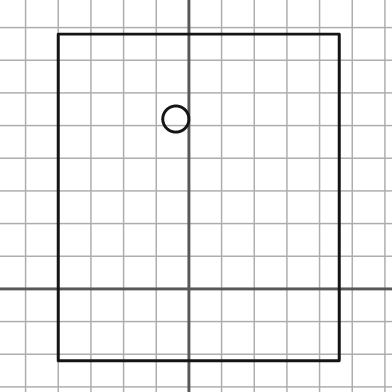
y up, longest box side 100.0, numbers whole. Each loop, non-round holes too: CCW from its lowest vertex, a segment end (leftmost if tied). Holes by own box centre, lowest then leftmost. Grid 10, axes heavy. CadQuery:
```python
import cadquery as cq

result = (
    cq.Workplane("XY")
    .moveTo(-40.0, -22.0)
    .lineTo(46.0, -22.0)
    .lineTo(46.0, 78.0)
    .lineTo(-40.0, 78.0)
    .close()
    .moveTo(-4.0, 52.0)
    .circle(4.0)
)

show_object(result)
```